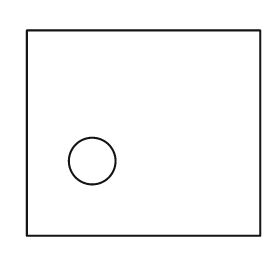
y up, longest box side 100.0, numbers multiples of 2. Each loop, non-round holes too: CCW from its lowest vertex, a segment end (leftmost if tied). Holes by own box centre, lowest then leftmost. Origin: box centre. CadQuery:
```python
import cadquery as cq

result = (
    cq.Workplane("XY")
    .moveTo(-50.0, -44.0)
    .lineTo(50.0, -44.0)
    .lineTo(50.0, 44.0)
    .lineTo(-50.0, 44.0)
    .close()
    .moveTo(-22.0, -12.0)
    .circle(10.0)
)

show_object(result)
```